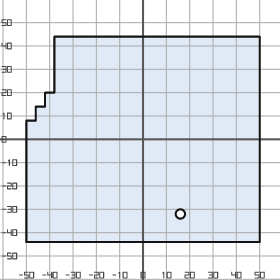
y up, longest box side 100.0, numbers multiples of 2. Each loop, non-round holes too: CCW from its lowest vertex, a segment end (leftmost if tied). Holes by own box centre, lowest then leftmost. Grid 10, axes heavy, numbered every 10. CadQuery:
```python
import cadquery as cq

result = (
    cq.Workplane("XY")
    .moveTo(-50.0, -44.0)
    .lineTo(50.0, -44.0)
    .lineTo(50.0, 44.0)
    .lineTo(-38.0, 44.0)
    .lineTo(-38.0, 20.0)
    .lineTo(-42.0, 20.0)
    .lineTo(-42.0, 14.0)
    .lineTo(-46.0, 14.0)
    .lineTo(-46.0, 8.0)
    .lineTo(-50.0, 8.0)
    .close()
    .moveTo(16.0, -32.0)
    .circle(2.0)
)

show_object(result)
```